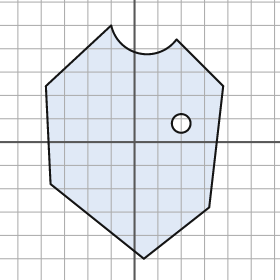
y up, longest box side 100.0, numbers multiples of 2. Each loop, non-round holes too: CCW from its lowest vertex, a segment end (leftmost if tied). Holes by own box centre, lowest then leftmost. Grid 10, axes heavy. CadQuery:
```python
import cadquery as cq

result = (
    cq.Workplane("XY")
    .moveTo(4.0, -50.0)
    .lineTo(32.0, -28.0)
    .lineTo(38.0, 24.0)
    .lineTo(18.0, 44.0)
    .threePointArc((2.0, 38.0), (-10.0, 50.0))
    .lineTo(-38.0, 24.0)
    .lineTo(-36.0, -18.0)
    .close()
    .moveTo(20.0, 8.0)
    .circle(4.0)
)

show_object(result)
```